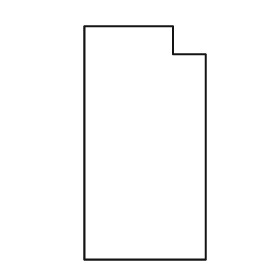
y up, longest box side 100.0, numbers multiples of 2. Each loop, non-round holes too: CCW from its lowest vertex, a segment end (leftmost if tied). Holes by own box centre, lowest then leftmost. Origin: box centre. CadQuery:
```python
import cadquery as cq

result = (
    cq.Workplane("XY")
    .moveTo(-26.0, -50.0)
    .lineTo(26.0, -50.0)
    .lineTo(26.0, 38.0)
    .lineTo(12.0, 38.0)
    .lineTo(12.0, 50.0)
    .lineTo(-26.0, 50.0)
    .close()
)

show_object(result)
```